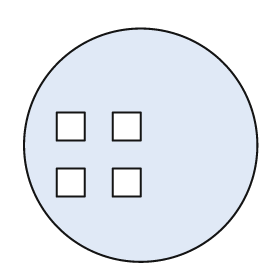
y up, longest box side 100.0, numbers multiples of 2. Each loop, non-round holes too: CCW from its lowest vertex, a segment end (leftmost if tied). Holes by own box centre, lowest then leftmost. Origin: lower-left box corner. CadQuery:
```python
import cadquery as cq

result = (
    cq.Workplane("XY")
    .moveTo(50.0, 50.0)
    .circle(50.0)
    .moveTo(14.0, 28.0)
    .lineTo(26.0, 28.0)
    .lineTo(26.0, 40.0)
    .lineTo(14.0, 40.0)
    .close()
    .moveTo(38.0, 28.0)
    .lineTo(50.0, 28.0)
    .lineTo(50.0, 40.0)
    .lineTo(38.0, 40.0)
    .close()
    .moveTo(14.0, 52.0)
    .lineTo(26.0, 52.0)
    .lineTo(26.0, 64.0)
    .lineTo(14.0, 64.0)
    .close()
    .moveTo(38.0, 52.0)
    .lineTo(50.0, 52.0)
    .lineTo(50.0, 64.0)
    .lineTo(38.0, 64.0)
    .close()
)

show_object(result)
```